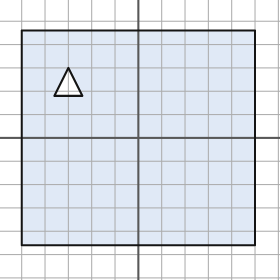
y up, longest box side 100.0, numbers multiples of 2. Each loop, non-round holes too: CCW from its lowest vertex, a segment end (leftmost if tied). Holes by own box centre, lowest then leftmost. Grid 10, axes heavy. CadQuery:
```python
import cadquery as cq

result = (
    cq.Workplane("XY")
    .moveTo(-50.0, -46.0)
    .lineTo(50.0, -46.0)
    .lineTo(50.0, 46.0)
    .lineTo(-50.0, 46.0)
    .close()
    .moveTo(-36.0, 18.0)
    .lineTo(-24.0, 18.0)
    .lineTo(-30.0, 30.0)
    .close()
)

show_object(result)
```